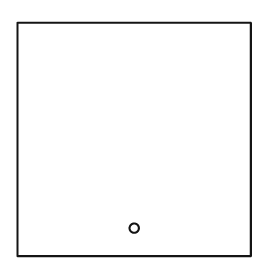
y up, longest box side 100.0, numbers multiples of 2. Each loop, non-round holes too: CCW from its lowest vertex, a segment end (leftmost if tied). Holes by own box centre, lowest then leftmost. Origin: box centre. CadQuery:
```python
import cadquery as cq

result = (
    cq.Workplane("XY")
    .moveTo(-50.0, -50.0)
    .lineTo(50.0, -50.0)
    .lineTo(50.0, 50.0)
    .lineTo(-50.0, 50.0)
    .close()
    .moveTo(0.0, -38.0)
    .circle(2.0)
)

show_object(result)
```